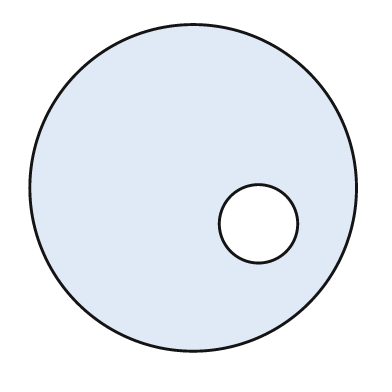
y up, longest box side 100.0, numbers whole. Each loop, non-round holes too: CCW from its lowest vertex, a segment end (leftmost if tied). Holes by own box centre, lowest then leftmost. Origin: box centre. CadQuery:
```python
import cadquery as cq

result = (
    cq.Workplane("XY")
    .moveTo(0.0, 0.0)
    .circle(50.0)
    .moveTo(20.0, -11.0)
    .circle(12.0)
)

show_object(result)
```